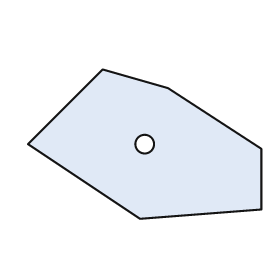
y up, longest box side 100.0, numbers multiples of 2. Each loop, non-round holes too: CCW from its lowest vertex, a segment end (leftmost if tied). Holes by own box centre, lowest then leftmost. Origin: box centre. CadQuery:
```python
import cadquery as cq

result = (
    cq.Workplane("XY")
    .moveTo(-2.0, -32.0)
    .lineTo(50.0, -28.0)
    .lineTo(50.0, -2.0)
    .lineTo(10.0, 24.0)
    .lineTo(-18.0, 32.0)
    .lineTo(-50.0, 0.0)
    .close()
    .moveTo(0.0, 0.0)
    .circle(4.0)
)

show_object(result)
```